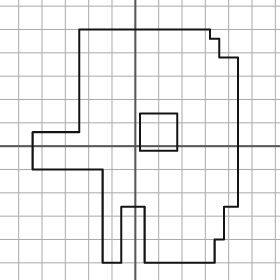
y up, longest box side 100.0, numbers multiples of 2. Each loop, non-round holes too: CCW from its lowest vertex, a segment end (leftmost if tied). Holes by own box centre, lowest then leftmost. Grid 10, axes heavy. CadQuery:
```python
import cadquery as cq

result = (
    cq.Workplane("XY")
    .moveTo(-14.0, -50.0)
    .lineTo(-6.0, -50.0)
    .lineTo(-6.0, -26.0)
    .lineTo(4.0, -26.0)
    .lineTo(4.0, -50.0)
    .lineTo(34.0, -50.0)
    .lineTo(34.0, -40.0)
    .lineTo(38.0, -40.0)
    .lineTo(38.0, -26.0)
    .lineTo(44.0, -26.0)
    .lineTo(44.0, 38.0)
    .lineTo(36.0, 38.0)
    .lineTo(36.0, 46.0)
    .lineTo(32.0, 46.0)
    .lineTo(32.0, 50.0)
    .lineTo(-24.0, 50.0)
    .lineTo(-24.0, 6.0)
    .lineTo(-44.0, 6.0)
    .lineTo(-44.0, -10.0)
    .lineTo(-14.0, -10.0)
    .close()
    .moveTo(2.0, -2.0)
    .lineTo(18.0, -2.0)
    .lineTo(18.0, 14.0)
    .lineTo(2.0, 14.0)
    .close()
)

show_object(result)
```